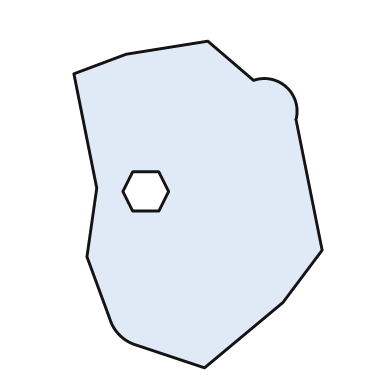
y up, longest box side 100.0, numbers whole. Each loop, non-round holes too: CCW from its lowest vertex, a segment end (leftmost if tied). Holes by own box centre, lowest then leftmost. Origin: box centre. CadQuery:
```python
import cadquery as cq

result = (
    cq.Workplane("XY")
    .moveTo(2.0, -50.0)
    .lineTo(26.0, -30.0)
    .lineTo(38.0, -14.0)
    .lineTo(30.0, 26.0)
    .threePointArc((27.0, 36.0), (17.0, 38.0))
    .lineTo(3.0, 50.0)
    .lineTo(-22.0, 46.0)
    .lineTo(-38.0, 40.0)
    .lineTo(-31.0, 5.0)
    .lineTo(-34.0, -16.0)
    .lineTo(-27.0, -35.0)
    .threePointArc((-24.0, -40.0), (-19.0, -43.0))
    .close()
    .moveTo(-20.0, -2.0)
    .lineTo(-12.0, -2.0)
    .lineTo(-9.0, 4.0)
    .lineTo(-12.0, 10.0)
    .lineTo(-20.0, 10.0)
    .lineTo(-23.0, 4.0)
    .close()
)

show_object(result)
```